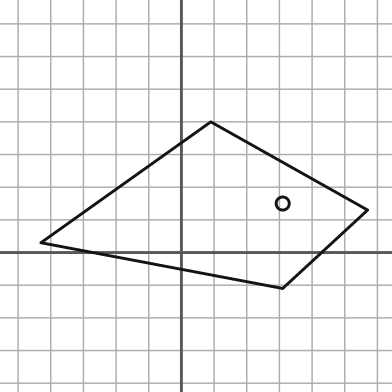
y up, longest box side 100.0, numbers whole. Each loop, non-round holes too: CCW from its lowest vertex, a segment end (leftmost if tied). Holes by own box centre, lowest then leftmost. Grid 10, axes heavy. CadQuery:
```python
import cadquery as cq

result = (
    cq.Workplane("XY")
    .moveTo(31.0, -11.0)
    .lineTo(57.0, 13.0)
    .lineTo(9.0, 40.0)
    .lineTo(-43.0, 3.0)
    .close()
    .moveTo(31.0, 15.0)
    .circle(2.0)
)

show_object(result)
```